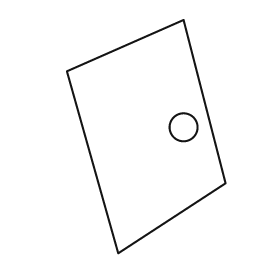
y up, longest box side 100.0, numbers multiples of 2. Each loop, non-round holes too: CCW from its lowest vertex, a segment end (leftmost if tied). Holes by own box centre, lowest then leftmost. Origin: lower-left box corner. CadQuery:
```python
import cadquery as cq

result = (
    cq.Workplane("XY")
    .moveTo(22.0, 0.0)
    .lineTo(68.0, 30.0)
    .lineTo(50.0, 100.0)
    .lineTo(0.0, 78.0)
    .close()
    .moveTo(50.0, 54.0)
    .circle(6.0)
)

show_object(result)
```